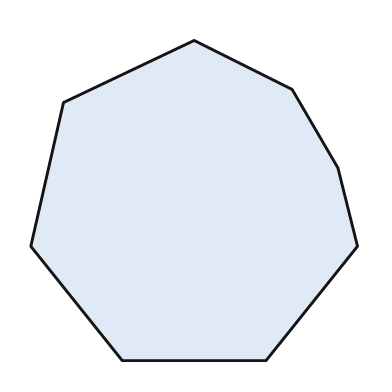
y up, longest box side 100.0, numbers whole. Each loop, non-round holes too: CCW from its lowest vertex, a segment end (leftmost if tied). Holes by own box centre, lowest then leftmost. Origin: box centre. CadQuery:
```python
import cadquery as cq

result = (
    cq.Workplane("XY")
    .moveTo(-22.0, -49.0)
    .lineTo(22.0, -49.0)
    .lineTo(50.0, -14.0)
    .lineTo(44.0, 10.0)
    .lineTo(30.0, 34.0)
    .lineTo(0.0, 49.0)
    .lineTo(-40.0, 30.0)
    .lineTo(-50.0, -14.0)
    .close()
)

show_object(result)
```